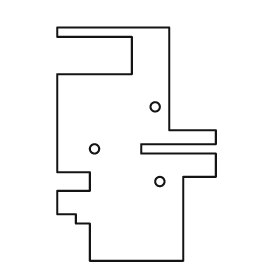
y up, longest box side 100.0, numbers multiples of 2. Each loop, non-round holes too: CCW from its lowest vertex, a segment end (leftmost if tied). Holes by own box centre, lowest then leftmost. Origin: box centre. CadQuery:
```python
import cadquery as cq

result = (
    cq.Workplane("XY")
    .moveTo(-20.0, -50.0)
    .lineTo(20.0, -50.0)
    .lineTo(20.0, -14.0)
    .lineTo(34.0, -14.0)
    .lineTo(34.0, -4.0)
    .lineTo(2.0, -4.0)
    .lineTo(2.0, 0.0)
    .lineTo(34.0, 0.0)
    .lineTo(34.0, 6.0)
    .lineTo(14.0, 6.0)
    .lineTo(14.0, 50.0)
    .lineTo(-34.0, 50.0)
    .lineTo(-34.0, 46.0)
    .lineTo(-2.0, 46.0)
    .lineTo(-2.0, 30.0)
    .lineTo(-34.0, 30.0)
    .lineTo(-34.0, -12.0)
    .lineTo(-20.0, -12.0)
    .lineTo(-20.0, -20.0)
    .lineTo(-34.0, -20.0)
    .lineTo(-34.0, -30.0)
    .lineTo(-26.0, -30.0)
    .lineTo(-26.0, -34.0)
    .lineTo(-20.0, -34.0)
    .close()
    .moveTo(10.0, -16.0)
    .circle(2.0)
    .moveTo(-18.0, -2.0)
    .circle(2.0)
    .moveTo(8.0, 16.0)
    .circle(2.0)
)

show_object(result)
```